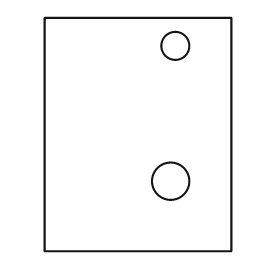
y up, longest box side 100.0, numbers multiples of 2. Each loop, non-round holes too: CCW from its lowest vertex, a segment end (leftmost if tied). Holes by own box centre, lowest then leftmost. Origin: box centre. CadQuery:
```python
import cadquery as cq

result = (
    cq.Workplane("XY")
    .moveTo(-40.0, -50.0)
    .lineTo(40.0, -50.0)
    .lineTo(40.0, 50.0)
    .lineTo(-40.0, 50.0)
    .close()
    .moveTo(14.0, -20.0)
    .circle(8.0)
    .moveTo(16.0, 38.0)
    .circle(6.0)
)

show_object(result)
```